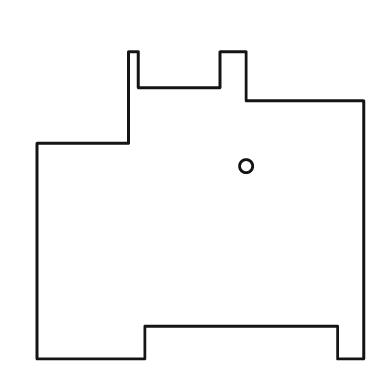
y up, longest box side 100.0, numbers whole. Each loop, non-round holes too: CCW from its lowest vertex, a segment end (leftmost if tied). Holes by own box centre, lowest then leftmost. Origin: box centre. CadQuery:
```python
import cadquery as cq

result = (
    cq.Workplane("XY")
    .moveTo(-50.0, -47.0)
    .lineTo(-17.0, -47.0)
    .lineTo(-17.0, -37.0)
    .lineTo(42.0, -37.0)
    .lineTo(42.0, -47.0)
    .lineTo(50.0, -47.0)
    .lineTo(50.0, 32.0)
    .lineTo(14.0, 32.0)
    .lineTo(14.0, 47.0)
    .lineTo(6.0, 47.0)
    .lineTo(6.0, 36.0)
    .lineTo(-19.0, 36.0)
    .lineTo(-19.0, 47.0)
    .lineTo(-22.0, 47.0)
    .lineTo(-22.0, 19.0)
    .lineTo(-50.0, 19.0)
    .close()
    .moveTo(14.0, 12.0)
    .circle(2.0)
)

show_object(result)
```